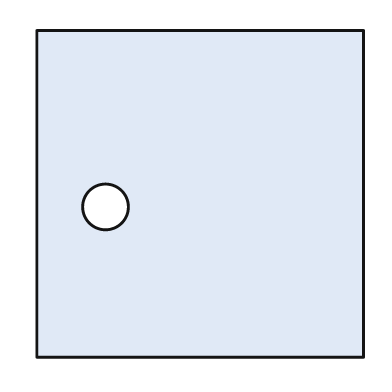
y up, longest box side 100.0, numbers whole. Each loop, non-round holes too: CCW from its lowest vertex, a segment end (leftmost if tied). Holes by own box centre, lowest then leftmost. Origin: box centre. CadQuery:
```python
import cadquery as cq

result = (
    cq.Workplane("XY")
    .moveTo(-50.0, -50.0)
    .lineTo(50.0, -50.0)
    .lineTo(50.0, 50.0)
    .lineTo(-50.0, 50.0)
    .close()
    .moveTo(-29.0, -4.0)
    .circle(7.0)
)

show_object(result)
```